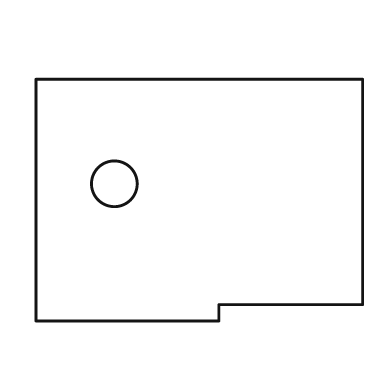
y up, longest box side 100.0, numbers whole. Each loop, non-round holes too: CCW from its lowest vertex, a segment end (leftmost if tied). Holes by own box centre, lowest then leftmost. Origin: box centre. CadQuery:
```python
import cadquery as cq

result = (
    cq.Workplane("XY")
    .moveTo(-50.0, -37.0)
    .lineTo(6.0, -37.0)
    .lineTo(6.0, -32.0)
    .lineTo(50.0, -32.0)
    .lineTo(50.0, 37.0)
    .lineTo(-50.0, 37.0)
    .close()
    .moveTo(-26.0, 5.0)
    .circle(7.0)
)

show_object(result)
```